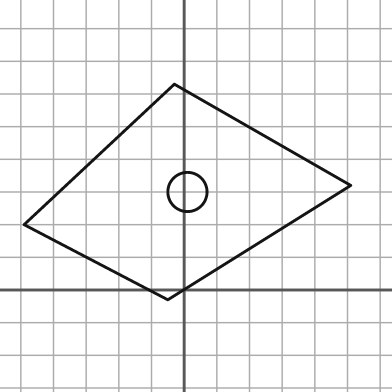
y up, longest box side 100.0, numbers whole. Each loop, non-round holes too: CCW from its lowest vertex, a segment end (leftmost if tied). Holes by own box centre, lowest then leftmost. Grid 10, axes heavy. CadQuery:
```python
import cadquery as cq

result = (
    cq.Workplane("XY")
    .moveTo(-5.0, -3.0)
    .lineTo(51.0, 32.0)
    .lineTo(-3.0, 63.0)
    .lineTo(-49.0, 20.0)
    .close()
    .moveTo(1.0, 30.0)
    .circle(6.0)
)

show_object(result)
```